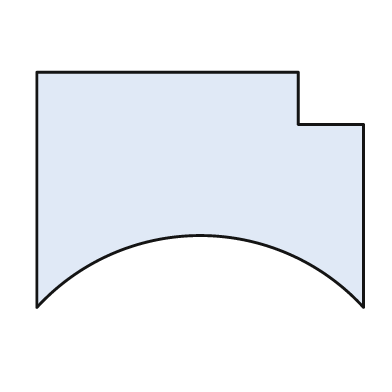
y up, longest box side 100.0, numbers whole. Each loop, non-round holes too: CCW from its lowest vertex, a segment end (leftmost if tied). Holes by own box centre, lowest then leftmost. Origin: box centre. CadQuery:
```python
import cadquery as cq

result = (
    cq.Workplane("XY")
    .moveTo(-50.0, -36.0)
    .threePointArc((0.0, -14.0), (50.0, -36.0))
    .lineTo(50.0, 20.0)
    .lineTo(30.0, 20.0)
    .lineTo(30.0, 36.0)
    .lineTo(-50.0, 36.0)
    .close()
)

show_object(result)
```